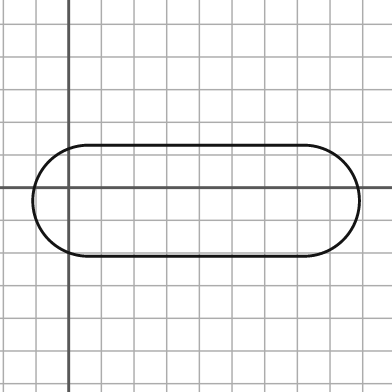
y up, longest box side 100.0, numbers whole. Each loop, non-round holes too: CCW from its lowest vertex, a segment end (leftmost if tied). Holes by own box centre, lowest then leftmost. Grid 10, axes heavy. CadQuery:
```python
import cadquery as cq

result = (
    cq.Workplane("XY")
    .moveTo(6.0, -21.0)
    .lineTo(72.0, -21.0)
    .threePointArc((89.0, -4.0), (72.0, 13.0))
    .lineTo(6.0, 13.0)
    .threePointArc((-11.0, -4.0), (6.0, -21.0))
    .close()
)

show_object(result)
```